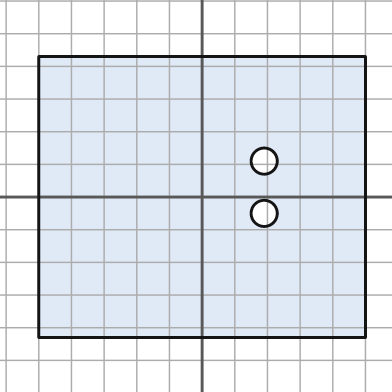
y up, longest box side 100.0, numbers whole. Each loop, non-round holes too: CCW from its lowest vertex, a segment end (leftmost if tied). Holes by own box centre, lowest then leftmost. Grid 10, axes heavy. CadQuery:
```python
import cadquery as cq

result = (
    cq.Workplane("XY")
    .moveTo(-50.0, -43.0)
    .lineTo(50.0, -43.0)
    .lineTo(50.0, 43.0)
    .lineTo(-50.0, 43.0)
    .close()
    .moveTo(19.0, -5.0)
    .circle(4.0)
    .moveTo(19.0, 11.0)
    .circle(4.0)
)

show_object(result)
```